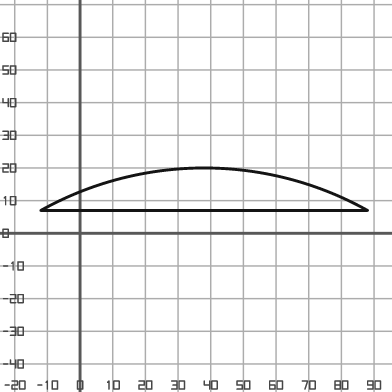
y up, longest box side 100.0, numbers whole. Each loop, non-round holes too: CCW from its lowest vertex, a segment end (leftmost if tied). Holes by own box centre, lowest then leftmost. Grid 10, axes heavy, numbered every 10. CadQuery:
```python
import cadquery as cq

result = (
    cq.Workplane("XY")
    .moveTo(-12.0, 7.0)
    .lineTo(88.0, 7.0)
    .threePointArc((38.0, 20.0), (-12.0, 7.0))
    .close()
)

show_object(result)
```